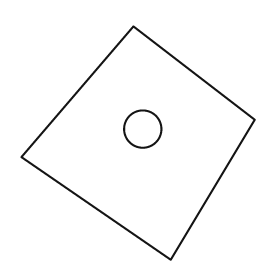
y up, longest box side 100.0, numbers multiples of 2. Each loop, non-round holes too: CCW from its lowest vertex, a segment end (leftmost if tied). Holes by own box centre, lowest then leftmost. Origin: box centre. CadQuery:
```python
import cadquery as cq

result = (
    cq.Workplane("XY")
    .moveTo(14.0, -50.0)
    .lineTo(50.0, 10.0)
    .lineTo(-2.0, 50.0)
    .lineTo(-50.0, -6.0)
    .close()
    .moveTo(2.0, 6.0)
    .circle(8.0)
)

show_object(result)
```